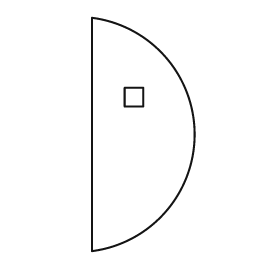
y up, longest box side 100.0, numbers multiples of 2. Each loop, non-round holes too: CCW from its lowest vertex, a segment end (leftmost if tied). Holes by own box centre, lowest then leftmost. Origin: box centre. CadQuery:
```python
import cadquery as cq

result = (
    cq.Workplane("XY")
    .moveTo(-22.0, -50.0)
    .threePointArc((22.0, 0.0), (-22.0, 50.0))
    .close()
    .moveTo(-8.0, 12.0)
    .lineTo(0.0, 12.0)
    .lineTo(0.0, 20.0)
    .lineTo(-8.0, 20.0)
    .close()
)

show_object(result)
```